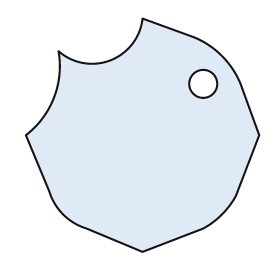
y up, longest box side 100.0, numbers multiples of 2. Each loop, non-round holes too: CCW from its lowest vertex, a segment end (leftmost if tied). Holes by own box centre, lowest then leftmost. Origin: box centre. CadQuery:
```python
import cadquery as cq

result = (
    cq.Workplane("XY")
    .moveTo(0.0, -50.0)
    .lineTo(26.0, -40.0)
    .threePointArc((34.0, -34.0), (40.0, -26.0))
    .lineTo(50.0, 0.0)
    .lineTo(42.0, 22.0)
    .threePointArc((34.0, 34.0), (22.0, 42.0))
    .lineTo(0.0, 50.0)
    .threePointArc((-14.0, 32.0), (-36.0, 36.0))
    .threePointArc((-38.0, 16.0), (-50.0, 0.0))
    .lineTo(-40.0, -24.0)
    .threePointArc((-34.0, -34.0), (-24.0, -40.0))
    .close()
    .moveTo(26.0, 22.0)
    .circle(6.0)
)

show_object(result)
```